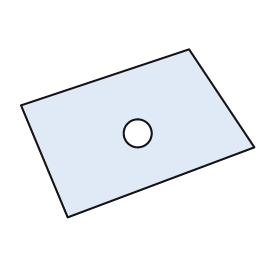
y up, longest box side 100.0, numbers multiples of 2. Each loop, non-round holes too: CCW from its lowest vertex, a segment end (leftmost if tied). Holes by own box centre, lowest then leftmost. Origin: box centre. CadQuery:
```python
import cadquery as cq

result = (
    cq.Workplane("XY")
    .moveTo(-30.0, -36.0)
    .lineTo(50.0, -6.0)
    .lineTo(22.0, 36.0)
    .lineTo(-50.0, 12.0)
    .close()
    .moveTo(0.0, 0.0)
    .circle(6.0)
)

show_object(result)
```